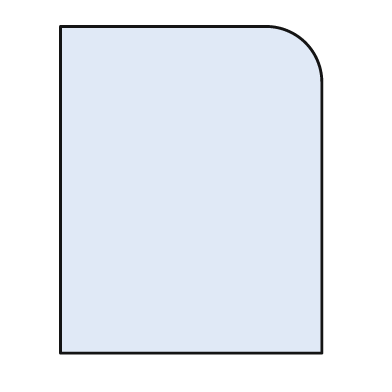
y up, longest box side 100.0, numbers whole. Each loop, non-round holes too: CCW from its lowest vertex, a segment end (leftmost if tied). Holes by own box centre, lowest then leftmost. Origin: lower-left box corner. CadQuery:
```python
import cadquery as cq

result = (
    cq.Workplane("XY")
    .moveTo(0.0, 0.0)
    .lineTo(80.0, 0.0)
    .lineTo(80.0, 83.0)
    .threePointArc((75.0, 95.0), (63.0, 100.0))
    .lineTo(0.0, 100.0)
    .close()
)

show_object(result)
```